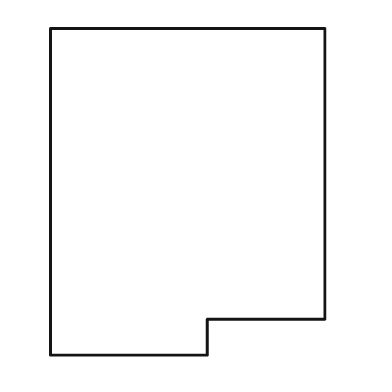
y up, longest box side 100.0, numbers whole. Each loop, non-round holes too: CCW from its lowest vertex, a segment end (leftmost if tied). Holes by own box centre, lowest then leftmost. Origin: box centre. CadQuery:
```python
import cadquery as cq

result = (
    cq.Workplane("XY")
    .moveTo(-42.0, -50.0)
    .lineTo(6.0, -50.0)
    .lineTo(6.0, -39.0)
    .lineTo(42.0, -39.0)
    .lineTo(42.0, 50.0)
    .lineTo(-42.0, 50.0)
    .close()
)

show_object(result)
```